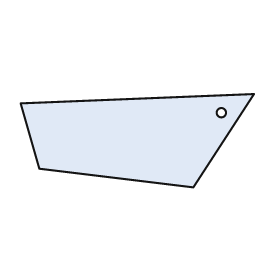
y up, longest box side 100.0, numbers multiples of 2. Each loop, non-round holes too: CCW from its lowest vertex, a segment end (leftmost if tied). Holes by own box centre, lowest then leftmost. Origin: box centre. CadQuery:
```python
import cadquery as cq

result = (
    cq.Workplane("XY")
    .moveTo(24.0, -20.0)
    .lineTo(50.0, 20.0)
    .lineTo(-50.0, 16.0)
    .lineTo(-42.0, -12.0)
    .close()
    .moveTo(36.0, 12.0)
    .circle(2.0)
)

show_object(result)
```